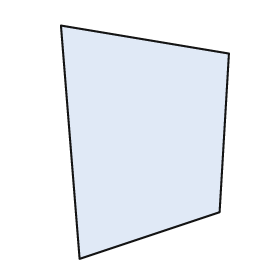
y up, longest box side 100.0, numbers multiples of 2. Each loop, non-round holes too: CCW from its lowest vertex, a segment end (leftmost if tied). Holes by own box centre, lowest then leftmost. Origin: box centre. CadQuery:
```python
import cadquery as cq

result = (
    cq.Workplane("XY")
    .moveTo(-28.0, -50.0)
    .lineTo(32.0, -30.0)
    .lineTo(36.0, 38.0)
    .lineTo(-36.0, 50.0)
    .close()
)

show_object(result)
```